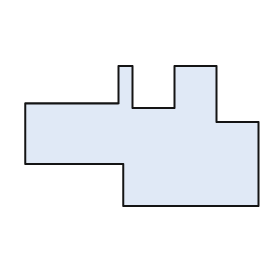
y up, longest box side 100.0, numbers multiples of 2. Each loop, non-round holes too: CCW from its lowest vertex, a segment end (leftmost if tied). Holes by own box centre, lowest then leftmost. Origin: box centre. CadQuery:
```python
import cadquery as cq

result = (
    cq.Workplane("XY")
    .moveTo(-8.0, -30.0)
    .lineTo(50.0, -30.0)
    .lineTo(50.0, 6.0)
    .lineTo(32.0, 6.0)
    .lineTo(32.0, 30.0)
    .lineTo(14.0, 30.0)
    .lineTo(14.0, 12.0)
    .lineTo(-4.0, 12.0)
    .lineTo(-4.0, 30.0)
    .lineTo(-10.0, 30.0)
    .lineTo(-10.0, 14.0)
    .lineTo(-50.0, 14.0)
    .lineTo(-50.0, -12.0)
    .lineTo(-8.0, -12.0)
    .close()
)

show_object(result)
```